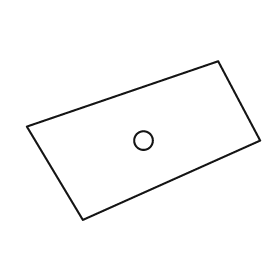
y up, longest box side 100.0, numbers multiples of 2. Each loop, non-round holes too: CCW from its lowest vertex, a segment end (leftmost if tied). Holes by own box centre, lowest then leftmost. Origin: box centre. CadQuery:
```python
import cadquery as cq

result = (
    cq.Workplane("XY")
    .moveTo(-26.0, -34.0)
    .lineTo(50.0, 0.0)
    .lineTo(32.0, 34.0)
    .lineTo(-50.0, 6.0)
    .close()
    .moveTo(0.0, 0.0)
    .circle(4.0)
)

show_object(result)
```